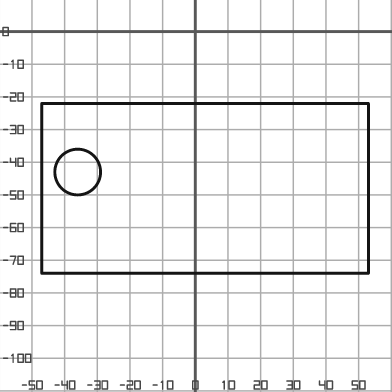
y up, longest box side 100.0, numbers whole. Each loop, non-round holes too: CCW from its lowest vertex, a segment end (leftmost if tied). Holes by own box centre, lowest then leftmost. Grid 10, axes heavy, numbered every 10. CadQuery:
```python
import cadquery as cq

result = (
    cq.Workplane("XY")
    .moveTo(-47.0, -74.0)
    .lineTo(53.0, -74.0)
    .lineTo(53.0, -22.0)
    .lineTo(-47.0, -22.0)
    .close()
    .moveTo(-36.0, -43.0)
    .circle(7.0)
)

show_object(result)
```